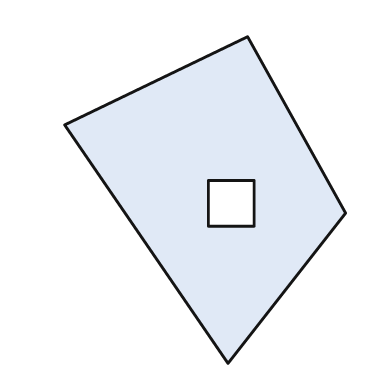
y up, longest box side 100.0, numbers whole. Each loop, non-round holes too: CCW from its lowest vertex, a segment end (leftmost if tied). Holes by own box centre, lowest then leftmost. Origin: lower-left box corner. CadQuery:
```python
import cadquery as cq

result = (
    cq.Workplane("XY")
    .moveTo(50.0, 0.0)
    .lineTo(86.0, 46.0)
    .lineTo(56.0, 100.0)
    .lineTo(0.0, 73.0)
    .close()
    .moveTo(44.0, 42.0)
    .lineTo(58.0, 42.0)
    .lineTo(58.0, 56.0)
    .lineTo(44.0, 56.0)
    .close()
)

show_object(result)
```